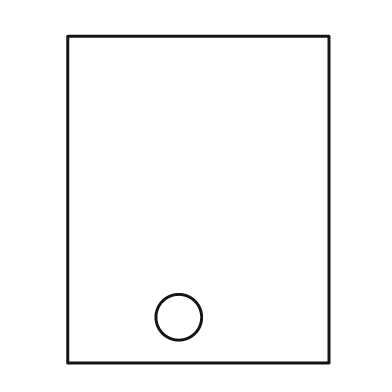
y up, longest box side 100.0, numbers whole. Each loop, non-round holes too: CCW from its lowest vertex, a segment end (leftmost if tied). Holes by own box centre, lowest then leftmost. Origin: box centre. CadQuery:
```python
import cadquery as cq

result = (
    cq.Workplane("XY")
    .moveTo(-40.0, -50.0)
    .lineTo(40.0, -50.0)
    .lineTo(40.0, 50.0)
    .lineTo(-40.0, 50.0)
    .close()
    .moveTo(-6.0, -36.0)
    .circle(7.0)
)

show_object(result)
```